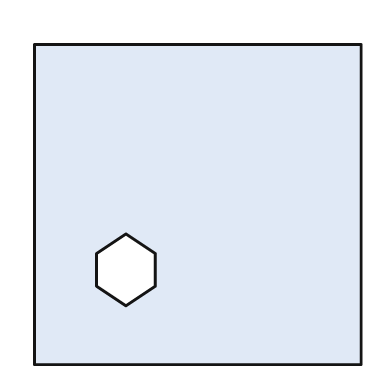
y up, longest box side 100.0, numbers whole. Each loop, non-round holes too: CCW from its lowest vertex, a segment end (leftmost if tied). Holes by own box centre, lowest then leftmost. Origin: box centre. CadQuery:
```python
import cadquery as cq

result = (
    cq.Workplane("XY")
    .moveTo(-50.0, -49.0)
    .lineTo(50.0, -49.0)
    .lineTo(50.0, 49.0)
    .lineTo(-50.0, 49.0)
    .close()
    .moveTo(-22.0, -31.0)
    .lineTo(-13.0, -25.0)
    .lineTo(-13.0, -15.0)
    .lineTo(-22.0, -9.0)
    .lineTo(-31.0, -15.0)
    .lineTo(-31.0, -25.0)
    .close()
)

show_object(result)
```